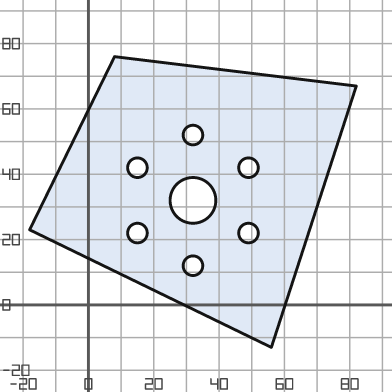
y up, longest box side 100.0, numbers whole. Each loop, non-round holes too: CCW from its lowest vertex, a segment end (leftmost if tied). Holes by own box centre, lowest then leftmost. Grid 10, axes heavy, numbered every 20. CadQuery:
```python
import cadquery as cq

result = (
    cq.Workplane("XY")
    .moveTo(56.0, -13.0)
    .lineTo(82.0, 67.0)
    .lineTo(8.0, 76.0)
    .lineTo(-18.0, 23.0)
    .close()
    .moveTo(32.0, 12.0)
    .circle(3.0)
    .moveTo(15.0, 22.0)
    .circle(3.0)
    .moveTo(49.0, 22.0)
    .circle(3.0)
    .moveTo(32.0, 32.0)
    .circle(7.0)
    .moveTo(15.0, 42.0)
    .circle(3.0)
    .moveTo(49.0, 42.0)
    .circle(3.0)
    .moveTo(32.0, 52.0)
    .circle(3.0)
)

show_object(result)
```